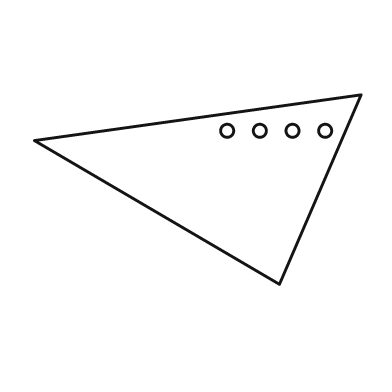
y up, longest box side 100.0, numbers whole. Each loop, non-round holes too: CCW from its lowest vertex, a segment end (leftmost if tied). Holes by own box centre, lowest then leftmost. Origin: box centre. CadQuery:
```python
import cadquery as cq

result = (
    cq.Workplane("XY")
    .moveTo(25.0, -29.0)
    .lineTo(50.0, 29.0)
    .lineTo(-50.0, 15.0)
    .close()
    .moveTo(9.0, 18.0)
    .circle(2.0)
    .moveTo(19.0, 18.0)
    .circle(2.0)
    .moveTo(29.0, 18.0)
    .circle(2.0)
    .moveTo(39.0, 18.0)
    .circle(2.0)
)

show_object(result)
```